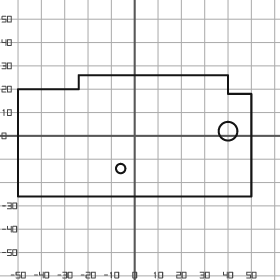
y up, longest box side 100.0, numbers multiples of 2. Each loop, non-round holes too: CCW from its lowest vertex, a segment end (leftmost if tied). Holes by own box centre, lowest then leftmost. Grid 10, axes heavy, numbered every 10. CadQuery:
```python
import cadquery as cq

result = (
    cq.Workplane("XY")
    .moveTo(-50.0, -26.0)
    .lineTo(50.0, -26.0)
    .lineTo(50.0, 18.0)
    .lineTo(40.0, 18.0)
    .lineTo(40.0, 26.0)
    .lineTo(-24.0, 26.0)
    .lineTo(-24.0, 20.0)
    .lineTo(-50.0, 20.0)
    .close()
    .moveTo(-6.0, -14.0)
    .circle(2.0)
    .moveTo(40.0, 2.0)
    .circle(4.0)
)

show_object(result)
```